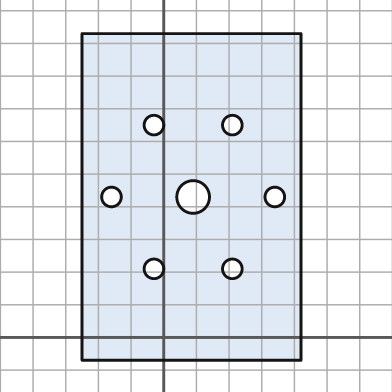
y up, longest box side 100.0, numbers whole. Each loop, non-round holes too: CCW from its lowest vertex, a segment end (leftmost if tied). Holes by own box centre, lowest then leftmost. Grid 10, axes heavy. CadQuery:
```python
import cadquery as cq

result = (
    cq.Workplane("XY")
    .moveTo(-25.0, -7.0)
    .lineTo(42.0, -7.0)
    .lineTo(42.0, 93.0)
    .lineTo(-25.0, 93.0)
    .close()
    .moveTo(-3.0, 21.0)
    .circle(3.0)
    .moveTo(21.0, 21.0)
    .circle(3.0)
    .moveTo(-16.0, 43.0)
    .circle(3.0)
    .moveTo(9.0, 43.0)
    .circle(5.0)
    .moveTo(34.0, 43.0)
    .circle(3.0)
    .moveTo(-3.0, 65.0)
    .circle(3.0)
    .moveTo(21.0, 65.0)
    .circle(3.0)
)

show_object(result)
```